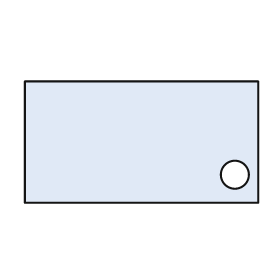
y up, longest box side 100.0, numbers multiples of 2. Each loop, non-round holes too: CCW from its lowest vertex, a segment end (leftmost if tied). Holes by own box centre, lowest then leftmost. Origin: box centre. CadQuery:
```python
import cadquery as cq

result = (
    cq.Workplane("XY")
    .moveTo(-50.0, -26.0)
    .lineTo(50.0, -26.0)
    .lineTo(50.0, 26.0)
    .lineTo(-50.0, 26.0)
    .close()
    .moveTo(40.0, -14.0)
    .circle(6.0)
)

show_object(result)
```